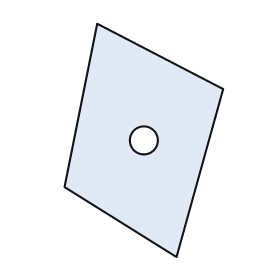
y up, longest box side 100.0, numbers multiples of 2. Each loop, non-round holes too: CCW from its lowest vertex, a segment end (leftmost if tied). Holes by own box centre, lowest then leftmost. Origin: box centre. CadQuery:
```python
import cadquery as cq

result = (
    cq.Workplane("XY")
    .moveTo(14.0, -50.0)
    .lineTo(34.0, 22.0)
    .lineTo(-20.0, 50.0)
    .lineTo(-34.0, -20.0)
    .close()
    .moveTo(0.0, 0.0)
    .circle(6.0)
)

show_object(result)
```